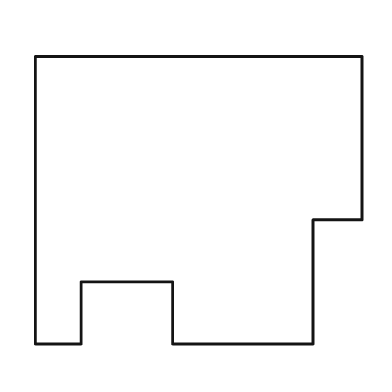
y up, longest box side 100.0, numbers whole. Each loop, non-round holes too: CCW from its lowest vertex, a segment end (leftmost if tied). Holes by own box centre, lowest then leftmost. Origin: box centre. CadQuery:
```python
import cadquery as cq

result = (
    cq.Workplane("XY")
    .moveTo(-50.0, -44.0)
    .lineTo(-36.0, -44.0)
    .lineTo(-36.0, -25.0)
    .lineTo(-8.0, -25.0)
    .lineTo(-8.0, -44.0)
    .lineTo(35.0, -44.0)
    .lineTo(35.0, -6.0)
    .lineTo(50.0, -6.0)
    .lineTo(50.0, 44.0)
    .lineTo(-50.0, 44.0)
    .close()
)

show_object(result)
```